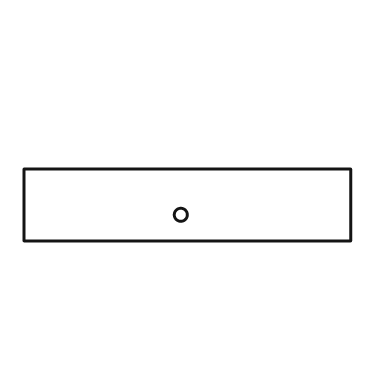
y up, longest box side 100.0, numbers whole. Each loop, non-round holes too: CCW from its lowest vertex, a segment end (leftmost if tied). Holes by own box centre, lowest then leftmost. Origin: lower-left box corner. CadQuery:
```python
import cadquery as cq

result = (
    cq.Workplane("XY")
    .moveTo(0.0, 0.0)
    .lineTo(100.0, 0.0)
    .lineTo(100.0, 22.0)
    .lineTo(0.0, 22.0)
    .close()
    .moveTo(48.0, 8.0)
    .circle(2.0)
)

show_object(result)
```